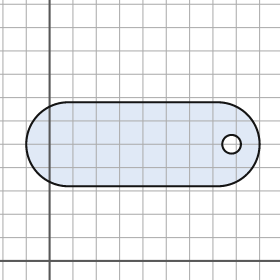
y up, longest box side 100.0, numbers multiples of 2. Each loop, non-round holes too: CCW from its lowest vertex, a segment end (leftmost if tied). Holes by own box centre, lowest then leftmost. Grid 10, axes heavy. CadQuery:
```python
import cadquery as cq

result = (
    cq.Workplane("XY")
    .moveTo(8.0, 32.0)
    .lineTo(72.0, 32.0)
    .threePointArc((90.0, 50.0), (72.0, 68.0))
    .lineTo(8.0, 68.0)
    .threePointArc((-10.0, 50.0), (8.0, 32.0))
    .close()
    .moveTo(78.0, 50.0)
    .circle(4.0)
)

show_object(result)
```